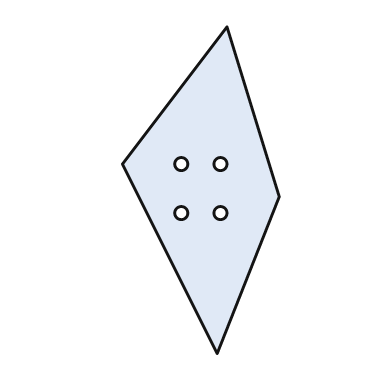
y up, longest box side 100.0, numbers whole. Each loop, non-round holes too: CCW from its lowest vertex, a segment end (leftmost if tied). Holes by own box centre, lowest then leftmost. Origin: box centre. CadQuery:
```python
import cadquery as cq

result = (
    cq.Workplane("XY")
    .moveTo(5.0, -50.0)
    .lineTo(24.0, -2.0)
    .lineTo(8.0, 50.0)
    .lineTo(-24.0, 8.0)
    .close()
    .moveTo(-6.0, -7.0)
    .circle(2.0)
    .moveTo(6.0, -7.0)
    .circle(2.0)
    .moveTo(-6.0, 8.0)
    .circle(2.0)
    .moveTo(6.0, 8.0)
    .circle(2.0)
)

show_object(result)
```